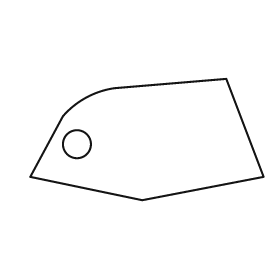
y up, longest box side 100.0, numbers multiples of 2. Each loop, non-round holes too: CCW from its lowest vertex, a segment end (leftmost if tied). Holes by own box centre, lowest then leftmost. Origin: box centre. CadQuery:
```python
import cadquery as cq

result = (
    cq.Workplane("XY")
    .moveTo(-2.0, -26.0)
    .lineTo(50.0, -16.0)
    .lineTo(34.0, 26.0)
    .lineTo(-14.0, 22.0)
    .threePointArc((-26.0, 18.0), (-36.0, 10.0))
    .lineTo(-50.0, -16.0)
    .close()
    .moveTo(-30.0, -2.0)
    .circle(6.0)
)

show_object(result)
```